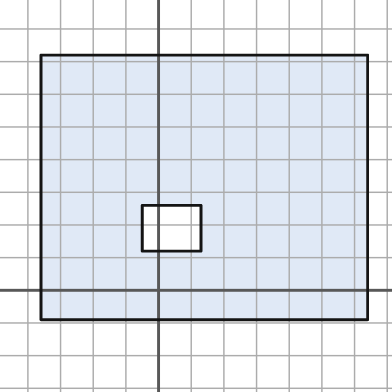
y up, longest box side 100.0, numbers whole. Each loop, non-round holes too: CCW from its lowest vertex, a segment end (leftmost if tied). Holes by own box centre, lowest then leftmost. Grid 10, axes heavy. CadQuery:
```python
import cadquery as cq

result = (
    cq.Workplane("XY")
    .moveTo(-36.0, -9.0)
    .lineTo(64.0, -9.0)
    .lineTo(64.0, 72.0)
    .lineTo(-36.0, 72.0)
    .close()
    .moveTo(-5.0, 12.0)
    .lineTo(13.0, 12.0)
    .lineTo(13.0, 26.0)
    .lineTo(-5.0, 26.0)
    .close()
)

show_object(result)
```